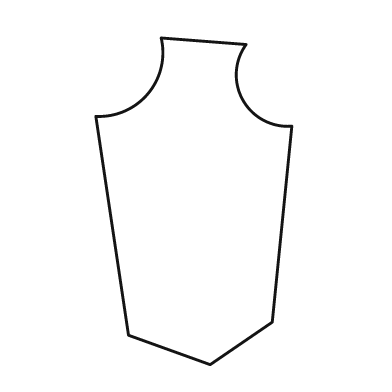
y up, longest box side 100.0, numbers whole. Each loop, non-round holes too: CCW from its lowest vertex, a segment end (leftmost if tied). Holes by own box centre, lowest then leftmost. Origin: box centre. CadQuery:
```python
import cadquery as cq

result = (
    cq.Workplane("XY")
    .moveTo(5.0, -50.0)
    .lineTo(24.0, -37.0)
    .lineTo(30.0, 23.0)
    .threePointArc((15.0, 31.0), (16.0, 48.0))
    .lineTo(-10.0, 50.0)
    .threePointArc((-14.0, 33.0), (-30.0, 26.0))
    .lineTo(-20.0, -41.0)
    .close()
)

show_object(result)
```